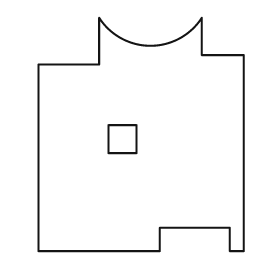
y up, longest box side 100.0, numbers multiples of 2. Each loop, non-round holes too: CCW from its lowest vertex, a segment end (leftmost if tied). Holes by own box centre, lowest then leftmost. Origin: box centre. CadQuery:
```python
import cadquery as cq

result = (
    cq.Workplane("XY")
    .moveTo(-44.0, -50.0)
    .lineTo(8.0, -50.0)
    .lineTo(8.0, -40.0)
    .lineTo(38.0, -40.0)
    .lineTo(38.0, -50.0)
    .lineTo(44.0, -50.0)
    .lineTo(44.0, 34.0)
    .lineTo(26.0, 34.0)
    .lineTo(26.0, 50.0)
    .threePointArc((4.0, 38.0), (-18.0, 50.0))
    .lineTo(-18.0, 30.0)
    .lineTo(-44.0, 30.0)
    .close()
    .moveTo(-14.0, -8.0)
    .lineTo(-2.0, -8.0)
    .lineTo(-2.0, 4.0)
    .lineTo(-14.0, 4.0)
    .close()
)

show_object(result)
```